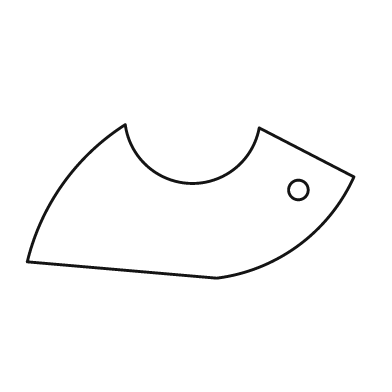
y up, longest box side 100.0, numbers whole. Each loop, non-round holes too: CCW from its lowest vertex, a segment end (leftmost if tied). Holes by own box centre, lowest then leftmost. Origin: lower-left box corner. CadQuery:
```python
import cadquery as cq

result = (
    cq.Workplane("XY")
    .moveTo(58.0, 0.0)
    .threePointArc((83.0, 10.0), (100.0, 31.0))
    .lineTo(71.0, 46.0)
    .threePointArc((50.0, 29.0), (30.0, 47.0))
    .threePointArc((11.0, 29.0), (0.0, 5.0))
    .close()
    .moveTo(83.0, 27.0)
    .circle(3.0)
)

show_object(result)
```